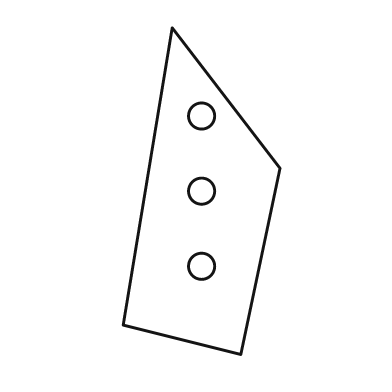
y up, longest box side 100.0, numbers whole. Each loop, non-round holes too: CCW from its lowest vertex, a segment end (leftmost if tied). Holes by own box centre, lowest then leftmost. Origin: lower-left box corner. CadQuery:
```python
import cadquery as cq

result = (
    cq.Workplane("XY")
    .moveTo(36.0, 0.0)
    .lineTo(48.0, 57.0)
    .lineTo(15.0, 100.0)
    .lineTo(0.0, 9.0)
    .close()
    .moveTo(24.0, 27.0)
    .circle(4.0)
    .moveTo(24.0, 50.0)
    .circle(4.0)
    .moveTo(24.0, 73.0)
    .circle(4.0)
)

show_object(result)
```